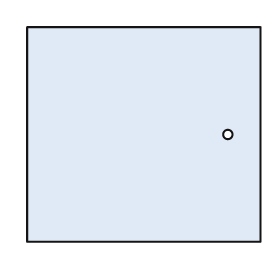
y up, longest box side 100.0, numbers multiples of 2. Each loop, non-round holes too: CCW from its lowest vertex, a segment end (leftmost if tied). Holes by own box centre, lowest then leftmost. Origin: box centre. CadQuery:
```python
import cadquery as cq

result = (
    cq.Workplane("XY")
    .moveTo(-50.0, -46.0)
    .lineTo(50.0, -46.0)
    .lineTo(50.0, 46.0)
    .lineTo(-50.0, 46.0)
    .close()
    .moveTo(36.0, 0.0)
    .circle(2.0)
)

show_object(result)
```